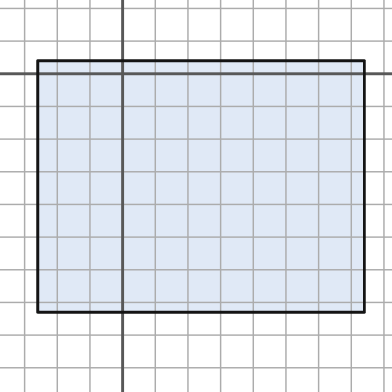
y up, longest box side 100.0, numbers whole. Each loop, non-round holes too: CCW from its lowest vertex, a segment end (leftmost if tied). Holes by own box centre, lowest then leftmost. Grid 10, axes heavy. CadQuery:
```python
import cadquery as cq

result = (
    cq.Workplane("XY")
    .moveTo(-26.0, -73.0)
    .lineTo(74.0, -73.0)
    .lineTo(74.0, 4.0)
    .lineTo(-26.0, 4.0)
    .close()
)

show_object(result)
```